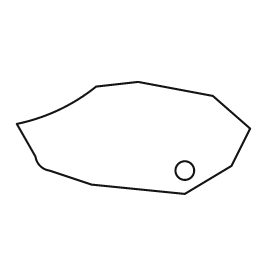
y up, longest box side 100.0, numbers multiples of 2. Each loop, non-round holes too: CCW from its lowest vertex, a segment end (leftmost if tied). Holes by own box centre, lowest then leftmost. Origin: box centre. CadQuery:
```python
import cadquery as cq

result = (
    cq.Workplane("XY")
    .moveTo(22.0, -24.0)
    .lineTo(42.0, -12.0)
    .lineTo(50.0, 4.0)
    .lineTo(34.0, 18.0)
    .lineTo(2.0, 24.0)
    .lineTo(-16.0, 22.0)
    .threePointArc((-32.0, 12.0), (-50.0, 6.0))
    .lineTo(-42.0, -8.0)
    .threePointArc((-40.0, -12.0), (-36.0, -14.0))
    .lineTo(-18.0, -20.0)
    .close()
    .moveTo(22.0, -14.0)
    .circle(4.0)
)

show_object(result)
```